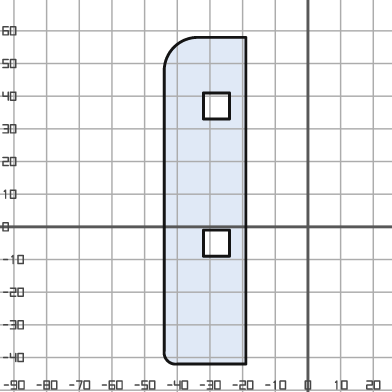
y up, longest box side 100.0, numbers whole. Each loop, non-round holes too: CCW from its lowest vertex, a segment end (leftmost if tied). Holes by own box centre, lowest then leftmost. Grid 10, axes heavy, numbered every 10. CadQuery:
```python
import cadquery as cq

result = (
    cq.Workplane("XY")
    .moveTo(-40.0, -42.0)
    .lineTo(-19.0, -42.0)
    .lineTo(-19.0, 58.0)
    .lineTo(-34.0, 58.0)
    .threePointArc((-41.0, 55.0), (-44.0, 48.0))
    .lineTo(-44.0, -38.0)
    .threePointArc((-43.0, -41.0), (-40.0, -42.0))
    .close()
    .moveTo(-32.0, -9.0)
    .lineTo(-24.0, -9.0)
    .lineTo(-24.0, -1.0)
    .lineTo(-32.0, -1.0)
    .close()
    .moveTo(-32.0, 33.0)
    .lineTo(-24.0, 33.0)
    .lineTo(-24.0, 41.0)
    .lineTo(-32.0, 41.0)
    .close()
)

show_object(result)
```